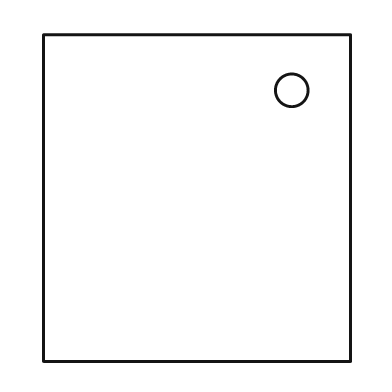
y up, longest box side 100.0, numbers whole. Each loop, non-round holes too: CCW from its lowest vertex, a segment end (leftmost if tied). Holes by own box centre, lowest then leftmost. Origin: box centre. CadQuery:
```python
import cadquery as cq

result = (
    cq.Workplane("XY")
    .moveTo(-47.0, -50.0)
    .lineTo(47.0, -50.0)
    .lineTo(47.0, 50.0)
    .lineTo(-47.0, 50.0)
    .close()
    .moveTo(29.0, 33.0)
    .circle(5.0)
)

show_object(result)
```